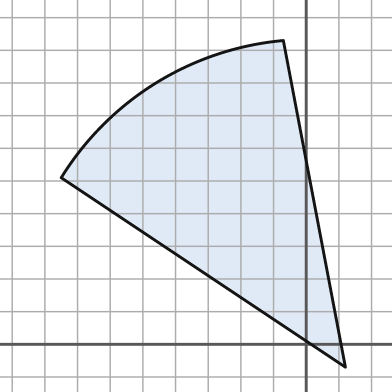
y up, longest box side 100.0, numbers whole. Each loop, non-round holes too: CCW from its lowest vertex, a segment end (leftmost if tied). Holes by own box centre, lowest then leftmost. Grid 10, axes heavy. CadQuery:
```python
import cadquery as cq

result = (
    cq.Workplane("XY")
    .moveTo(12.0, -7.0)
    .lineTo(-7.0, 93.0)
    .threePointArc((-46.0, 80.0), (-75.0, 51.0))
    .close()
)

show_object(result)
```